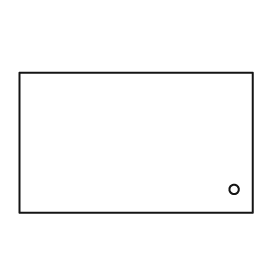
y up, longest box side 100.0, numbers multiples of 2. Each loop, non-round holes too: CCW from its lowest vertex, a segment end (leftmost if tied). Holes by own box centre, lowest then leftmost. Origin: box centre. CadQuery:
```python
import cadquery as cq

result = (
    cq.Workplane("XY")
    .moveTo(-50.0, -30.0)
    .lineTo(50.0, -30.0)
    .lineTo(50.0, 30.0)
    .lineTo(-50.0, 30.0)
    .close()
    .moveTo(42.0, -20.0)
    .circle(2.0)
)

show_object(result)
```